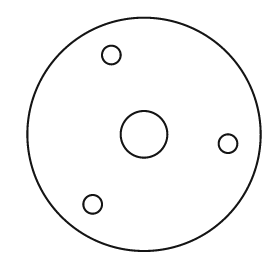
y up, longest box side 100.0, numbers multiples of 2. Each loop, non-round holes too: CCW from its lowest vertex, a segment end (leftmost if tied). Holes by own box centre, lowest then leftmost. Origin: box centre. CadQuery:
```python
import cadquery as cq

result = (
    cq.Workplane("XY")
    .moveTo(0.0, 0.0)
    .circle(50.0)
    .moveTo(-22.0, -30.0)
    .circle(4.0)
    .moveTo(36.0, -4.0)
    .circle(4.0)
    .moveTo(0.0, 0.0)
    .circle(10.0)
    .moveTo(-14.0, 34.0)
    .circle(4.0)
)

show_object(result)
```